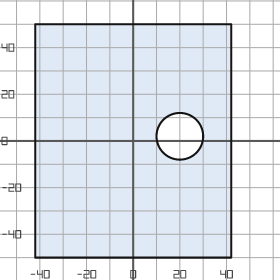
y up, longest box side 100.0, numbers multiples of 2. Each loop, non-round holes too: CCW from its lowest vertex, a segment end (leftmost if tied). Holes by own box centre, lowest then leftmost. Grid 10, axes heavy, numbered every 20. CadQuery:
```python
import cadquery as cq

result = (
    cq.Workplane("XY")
    .moveTo(-42.0, -50.0)
    .lineTo(42.0, -50.0)
    .lineTo(42.0, 50.0)
    .lineTo(-42.0, 50.0)
    .close()
    .moveTo(20.0, 2.0)
    .circle(10.0)
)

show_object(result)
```